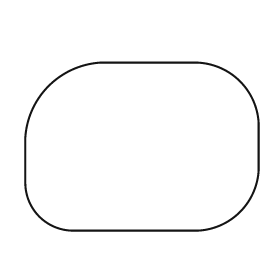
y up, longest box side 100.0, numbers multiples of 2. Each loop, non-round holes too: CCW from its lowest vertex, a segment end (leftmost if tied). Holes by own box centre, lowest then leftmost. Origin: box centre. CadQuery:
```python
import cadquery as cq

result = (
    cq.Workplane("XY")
    .moveTo(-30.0, -36.0)
    .lineTo(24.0, -36.0)
    .threePointArc((42.0, -28.0), (50.0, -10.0))
    .lineTo(50.0, 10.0)
    .threePointArc((42.0, 28.0), (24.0, 36.0))
    .lineTo(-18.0, 36.0)
    .threePointArc((-40.0, 26.0), (-50.0, 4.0))
    .lineTo(-50.0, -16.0)
    .threePointArc((-44.0, -30.0), (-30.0, -36.0))
    .close()
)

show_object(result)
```